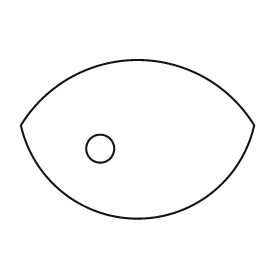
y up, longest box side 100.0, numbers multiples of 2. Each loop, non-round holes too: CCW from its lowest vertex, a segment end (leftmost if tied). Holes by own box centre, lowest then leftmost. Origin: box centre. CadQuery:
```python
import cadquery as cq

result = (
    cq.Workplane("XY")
    .moveTo(-50.0, 6.0)
    .threePointArc((0.0, -34.0), (50.0, 6.0))
    .threePointArc((0.0, 34.0), (-50.0, 6.0))
    .close()
    .moveTo(-16.0, -4.0)
    .circle(6.0)
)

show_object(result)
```